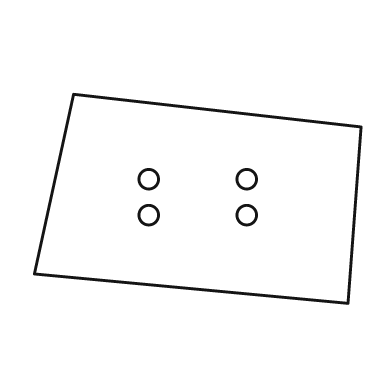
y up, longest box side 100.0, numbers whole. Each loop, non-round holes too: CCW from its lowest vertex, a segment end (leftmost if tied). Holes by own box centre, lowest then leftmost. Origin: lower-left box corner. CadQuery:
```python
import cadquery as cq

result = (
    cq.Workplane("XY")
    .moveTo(96.0, 0.0)
    .lineTo(100.0, 54.0)
    .lineTo(12.0, 64.0)
    .lineTo(0.0, 9.0)
    .close()
    .moveTo(35.0, 27.0)
    .circle(3.0)
    .moveTo(65.0, 27.0)
    .circle(3.0)
    .moveTo(35.0, 38.0)
    .circle(3.0)
    .moveTo(65.0, 38.0)
    .circle(3.0)
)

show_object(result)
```